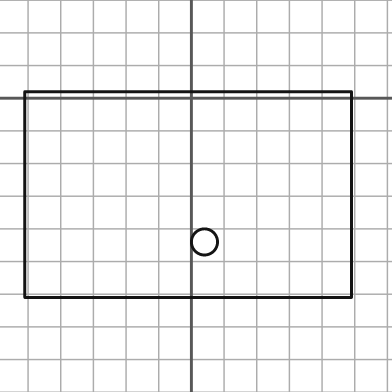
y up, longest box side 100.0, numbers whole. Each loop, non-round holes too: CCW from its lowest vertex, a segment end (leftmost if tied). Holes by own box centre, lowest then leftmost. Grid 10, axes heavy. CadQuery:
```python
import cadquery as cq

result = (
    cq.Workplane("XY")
    .moveTo(-51.0, -61.0)
    .lineTo(49.0, -61.0)
    .lineTo(49.0, 2.0)
    .lineTo(-51.0, 2.0)
    .close()
    .moveTo(4.0, -44.0)
    .circle(4.0)
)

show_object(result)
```